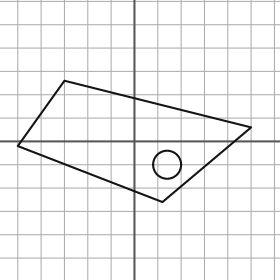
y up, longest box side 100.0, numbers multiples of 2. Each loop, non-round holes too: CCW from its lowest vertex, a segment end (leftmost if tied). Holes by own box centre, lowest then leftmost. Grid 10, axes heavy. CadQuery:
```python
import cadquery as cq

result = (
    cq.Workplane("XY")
    .moveTo(12.0, -26.0)
    .lineTo(50.0, 6.0)
    .lineTo(-30.0, 26.0)
    .lineTo(-50.0, -2.0)
    .close()
    .moveTo(14.0, -10.0)
    .circle(6.0)
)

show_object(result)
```